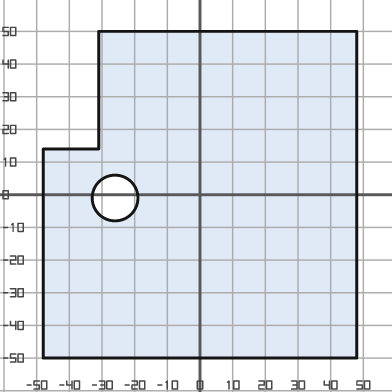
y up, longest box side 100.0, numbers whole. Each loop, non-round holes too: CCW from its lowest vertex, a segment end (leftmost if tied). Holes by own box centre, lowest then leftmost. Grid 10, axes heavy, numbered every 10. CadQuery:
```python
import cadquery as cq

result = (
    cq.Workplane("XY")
    .moveTo(-48.0, -50.0)
    .lineTo(48.0, -50.0)
    .lineTo(48.0, 50.0)
    .lineTo(-31.0, 50.0)
    .lineTo(-31.0, 14.0)
    .lineTo(-48.0, 14.0)
    .close()
    .moveTo(-26.0, -1.0)
    .circle(7.0)
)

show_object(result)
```